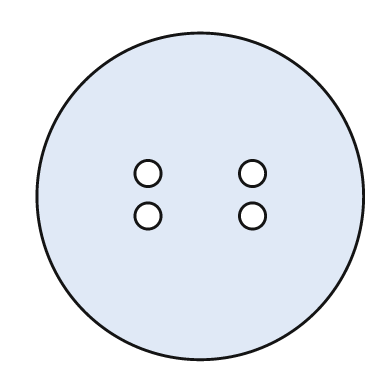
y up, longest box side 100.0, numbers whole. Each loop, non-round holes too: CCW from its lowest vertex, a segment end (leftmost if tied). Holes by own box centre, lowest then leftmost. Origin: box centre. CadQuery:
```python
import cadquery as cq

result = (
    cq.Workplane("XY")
    .moveTo(0.0, 0.0)
    .circle(50.0)
    .moveTo(-16.0, -6.0)
    .circle(4.0)
    .moveTo(16.0, -6.0)
    .circle(4.0)
    .moveTo(-16.0, 7.0)
    .circle(4.0)
    .moveTo(16.0, 7.0)
    .circle(4.0)
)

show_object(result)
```